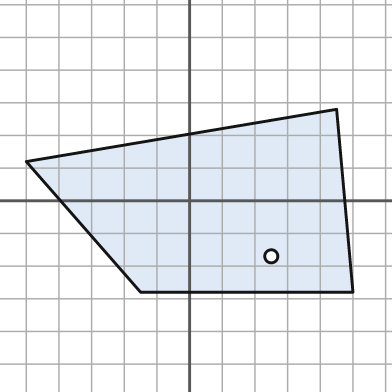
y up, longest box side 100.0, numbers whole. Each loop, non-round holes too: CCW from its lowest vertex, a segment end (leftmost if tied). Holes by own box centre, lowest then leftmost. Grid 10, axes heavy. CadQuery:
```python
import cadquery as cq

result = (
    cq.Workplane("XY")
    .moveTo(-15.0, -28.0)
    .lineTo(50.0, -28.0)
    .lineTo(45.0, 28.0)
    .lineTo(-50.0, 12.0)
    .close()
    .moveTo(25.0, -17.0)
    .circle(2.0)
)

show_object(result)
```